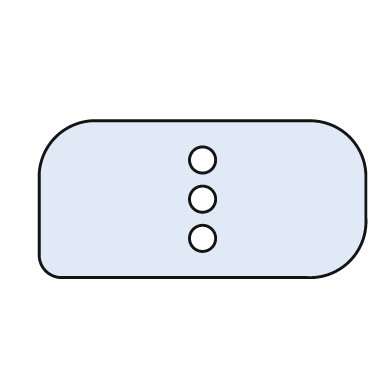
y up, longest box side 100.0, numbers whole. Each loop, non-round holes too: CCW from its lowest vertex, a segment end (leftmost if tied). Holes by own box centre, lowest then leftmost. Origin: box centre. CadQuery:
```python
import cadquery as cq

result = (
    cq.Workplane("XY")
    .moveTo(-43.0, -24.0)
    .lineTo(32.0, -24.0)
    .threePointArc((45.0, -19.0), (50.0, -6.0))
    .lineTo(50.0, 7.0)
    .threePointArc((45.0, 19.0), (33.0, 24.0))
    .lineTo(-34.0, 24.0)
    .threePointArc((-45.0, 19.0), (-50.0, 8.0))
    .lineTo(-50.0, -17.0)
    .threePointArc((-48.0, -22.0), (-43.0, -24.0))
    .close()
    .moveTo(0.0, -12.0)
    .circle(4.0)
    .moveTo(0.0, 0.0)
    .circle(4.0)
    .moveTo(0.0, 12.0)
    .circle(4.0)
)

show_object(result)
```